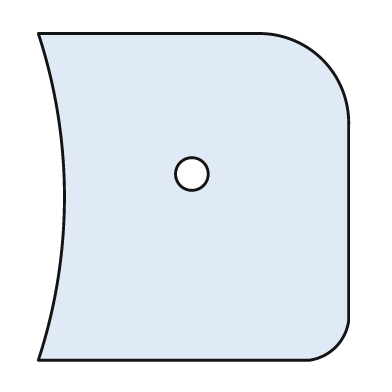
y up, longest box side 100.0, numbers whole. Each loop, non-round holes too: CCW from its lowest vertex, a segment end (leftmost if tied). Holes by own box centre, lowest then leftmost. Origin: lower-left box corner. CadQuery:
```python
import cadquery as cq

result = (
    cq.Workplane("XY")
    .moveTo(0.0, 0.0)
    .lineTo(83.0, 0.0)
    .threePointArc((91.0, 4.0), (95.0, 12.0))
    .lineTo(95.0, 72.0)
    .threePointArc((87.0, 92.0), (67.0, 100.0))
    .lineTo(0.0, 100.0)
    .threePointArc((8.0, 50.0), (0.0, 0.0))
    .close()
    .moveTo(47.0, 57.0)
    .circle(5.0)
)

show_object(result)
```